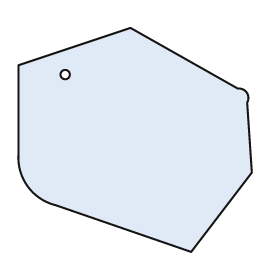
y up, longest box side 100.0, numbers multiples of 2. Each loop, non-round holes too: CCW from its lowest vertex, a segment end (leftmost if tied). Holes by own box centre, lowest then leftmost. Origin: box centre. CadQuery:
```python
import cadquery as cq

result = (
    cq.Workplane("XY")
    .moveTo(24.0, -48.0)
    .lineTo(50.0, -14.0)
    .lineTo(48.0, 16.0)
    .threePointArc((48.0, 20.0), (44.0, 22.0))
    .lineTo(-2.0, 48.0)
    .lineTo(-50.0, 32.0)
    .lineTo(-50.0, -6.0)
    .threePointArc((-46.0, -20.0), (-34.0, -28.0))
    .close()
    .moveTo(-30.0, 28.0)
    .circle(2.0)
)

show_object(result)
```